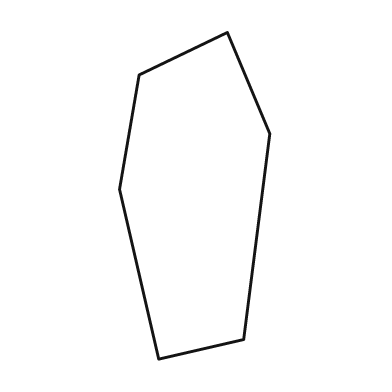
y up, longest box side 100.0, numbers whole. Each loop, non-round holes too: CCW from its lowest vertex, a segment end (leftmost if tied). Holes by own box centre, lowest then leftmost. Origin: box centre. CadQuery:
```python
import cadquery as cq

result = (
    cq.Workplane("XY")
    .moveTo(-11.0, -50.0)
    .lineTo(15.0, -44.0)
    .lineTo(23.0, 19.0)
    .lineTo(10.0, 50.0)
    .lineTo(-17.0, 37.0)
    .lineTo(-23.0, 2.0)
    .close()
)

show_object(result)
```